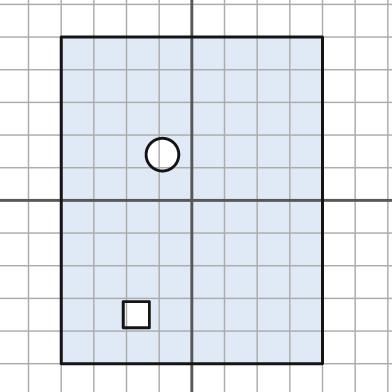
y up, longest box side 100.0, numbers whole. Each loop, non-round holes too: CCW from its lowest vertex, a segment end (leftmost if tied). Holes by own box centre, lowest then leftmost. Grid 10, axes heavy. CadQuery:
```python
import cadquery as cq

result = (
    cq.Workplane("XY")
    .moveTo(-40.0, -50.0)
    .lineTo(40.0, -50.0)
    .lineTo(40.0, 50.0)
    .lineTo(-40.0, 50.0)
    .close()
    .moveTo(-21.0, -39.0)
    .lineTo(-13.0, -39.0)
    .lineTo(-13.0, -31.0)
    .lineTo(-21.0, -31.0)
    .close()
    .moveTo(-9.0, 14.0)
    .circle(5.0)
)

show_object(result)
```